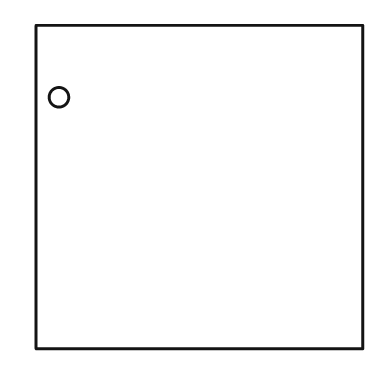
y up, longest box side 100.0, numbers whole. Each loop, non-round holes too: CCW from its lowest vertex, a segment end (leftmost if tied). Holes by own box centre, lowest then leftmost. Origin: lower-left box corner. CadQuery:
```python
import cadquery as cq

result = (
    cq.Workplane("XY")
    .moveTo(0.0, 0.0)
    .lineTo(100.0, 0.0)
    .lineTo(100.0, 99.0)
    .lineTo(0.0, 99.0)
    .close()
    .moveTo(7.0, 77.0)
    .circle(3.0)
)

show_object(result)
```